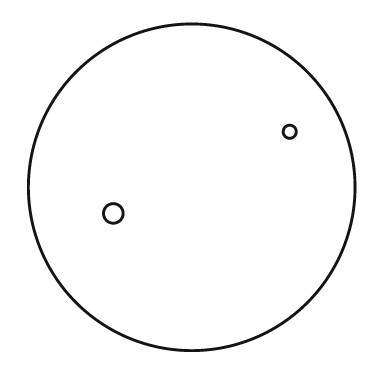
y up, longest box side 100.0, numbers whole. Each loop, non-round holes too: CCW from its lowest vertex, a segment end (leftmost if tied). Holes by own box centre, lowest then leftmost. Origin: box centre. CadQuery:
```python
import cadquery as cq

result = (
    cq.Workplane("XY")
    .moveTo(0.0, 0.0)
    .circle(50.0)
    .moveTo(-24.0, -8.0)
    .circle(3.0)
    .moveTo(30.0, 17.0)
    .circle(2.0)
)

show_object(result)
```